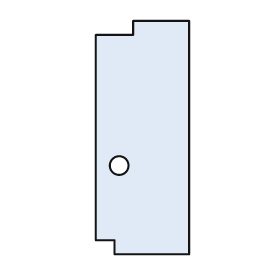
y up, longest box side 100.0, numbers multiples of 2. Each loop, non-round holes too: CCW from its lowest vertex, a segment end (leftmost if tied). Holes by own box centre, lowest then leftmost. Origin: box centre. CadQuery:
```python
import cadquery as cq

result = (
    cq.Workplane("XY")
    .moveTo(-12.0, -50.0)
    .lineTo(20.0, -50.0)
    .lineTo(20.0, 50.0)
    .lineTo(-4.0, 50.0)
    .lineTo(-4.0, 44.0)
    .lineTo(-20.0, 44.0)
    .lineTo(-20.0, -44.0)
    .lineTo(-12.0, -44.0)
    .close()
    .moveTo(-10.0, -12.0)
    .circle(4.0)
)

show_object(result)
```